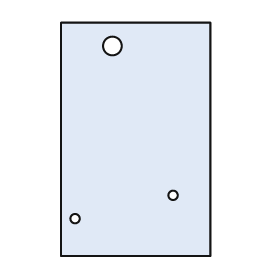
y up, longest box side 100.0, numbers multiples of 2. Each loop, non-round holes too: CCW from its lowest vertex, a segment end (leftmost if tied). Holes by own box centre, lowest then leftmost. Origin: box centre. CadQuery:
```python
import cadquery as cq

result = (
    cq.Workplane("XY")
    .moveTo(-32.0, -50.0)
    .lineTo(32.0, -50.0)
    .lineTo(32.0, 50.0)
    .lineTo(-32.0, 50.0)
    .close()
    .moveTo(-26.0, -34.0)
    .circle(2.0)
    .moveTo(16.0, -24.0)
    .circle(2.0)
    .moveTo(-10.0, 40.0)
    .circle(4.0)
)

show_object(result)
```